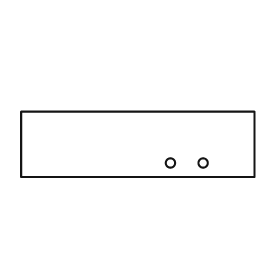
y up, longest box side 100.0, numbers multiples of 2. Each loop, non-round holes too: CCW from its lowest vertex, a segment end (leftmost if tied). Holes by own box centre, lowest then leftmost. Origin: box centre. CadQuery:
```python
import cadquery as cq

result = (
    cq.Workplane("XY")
    .moveTo(-50.0, -14.0)
    .lineTo(50.0, -14.0)
    .lineTo(50.0, 14.0)
    .lineTo(-50.0, 14.0)
    .close()
    .moveTo(14.0, -8.0)
    .circle(2.0)
    .moveTo(28.0, -8.0)
    .circle(2.0)
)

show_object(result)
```